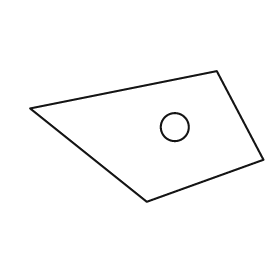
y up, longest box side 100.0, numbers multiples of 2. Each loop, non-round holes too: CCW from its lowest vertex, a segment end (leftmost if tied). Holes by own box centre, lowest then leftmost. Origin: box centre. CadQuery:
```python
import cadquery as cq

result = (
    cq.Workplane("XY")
    .moveTo(0.0, -28.0)
    .lineTo(50.0, -10.0)
    .lineTo(30.0, 28.0)
    .lineTo(-50.0, 12.0)
    .close()
    .moveTo(12.0, 4.0)
    .circle(6.0)
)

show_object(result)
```